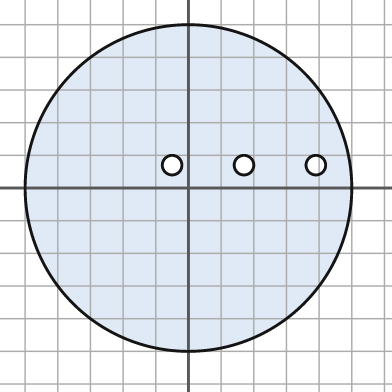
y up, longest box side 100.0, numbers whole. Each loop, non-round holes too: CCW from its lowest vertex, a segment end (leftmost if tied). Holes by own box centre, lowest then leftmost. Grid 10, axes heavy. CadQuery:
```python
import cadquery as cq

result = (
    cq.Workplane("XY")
    .moveTo(0.0, 0.0)
    .circle(50.0)
    .moveTo(-5.0, 7.0)
    .circle(3.0)
    .moveTo(17.0, 7.0)
    .circle(3.0)
    .moveTo(39.0, 7.0)
    .circle(3.0)
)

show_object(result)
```